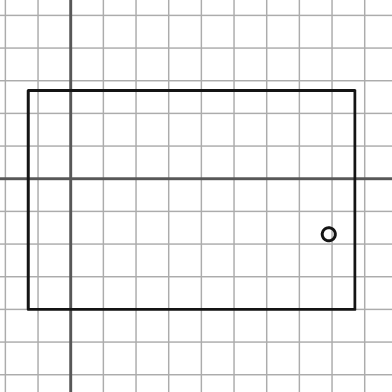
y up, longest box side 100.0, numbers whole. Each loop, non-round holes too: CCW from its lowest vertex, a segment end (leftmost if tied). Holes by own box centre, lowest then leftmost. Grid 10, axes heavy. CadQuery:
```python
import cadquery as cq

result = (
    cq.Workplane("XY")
    .moveTo(-13.0, -40.0)
    .lineTo(87.0, -40.0)
    .lineTo(87.0, 27.0)
    .lineTo(-13.0, 27.0)
    .close()
    .moveTo(79.0, -17.0)
    .circle(2.0)
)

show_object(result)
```